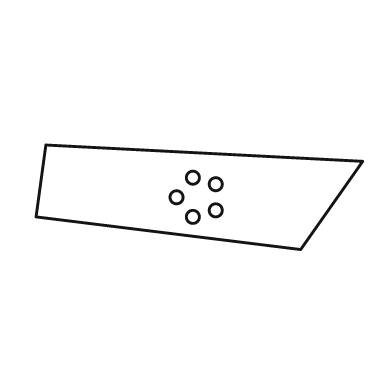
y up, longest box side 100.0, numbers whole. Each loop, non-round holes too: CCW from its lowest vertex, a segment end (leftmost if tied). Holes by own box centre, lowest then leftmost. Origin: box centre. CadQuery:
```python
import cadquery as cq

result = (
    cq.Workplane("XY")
    .moveTo(31.0, -16.0)
    .lineTo(50.0, 11.0)
    .lineTo(-47.0, 16.0)
    .lineTo(-50.0, -6.0)
    .close()
    .moveTo(-2.0, -6.0)
    .circle(2.0)
    .moveTo(5.0, -4.0)
    .circle(2.0)
    .moveTo(-7.0, 0.0)
    .circle(2.0)
    .moveTo(5.0, 4.0)
    .circle(2.0)
    .moveTo(-2.0, 6.0)
    .circle(2.0)
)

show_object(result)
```